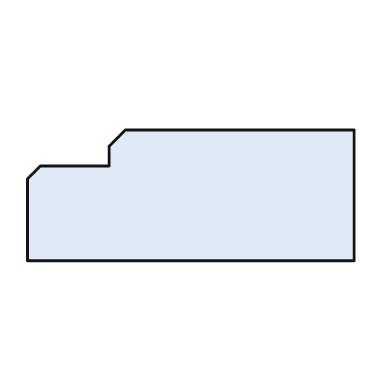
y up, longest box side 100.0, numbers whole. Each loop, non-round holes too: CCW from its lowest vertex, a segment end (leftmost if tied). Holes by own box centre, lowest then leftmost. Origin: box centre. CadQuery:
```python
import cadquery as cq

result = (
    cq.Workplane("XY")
    .moveTo(-50.0, -20.0)
    .lineTo(50.0, -20.0)
    .lineTo(50.0, 20.0)
    .lineTo(-20.0, 20.0)
    .lineTo(-25.0, 15.0)
    .lineTo(-25.0, 9.0)
    .lineTo(-46.0, 9.0)
    .lineTo(-50.0, 5.0)
    .close()
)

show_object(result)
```